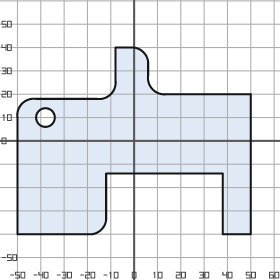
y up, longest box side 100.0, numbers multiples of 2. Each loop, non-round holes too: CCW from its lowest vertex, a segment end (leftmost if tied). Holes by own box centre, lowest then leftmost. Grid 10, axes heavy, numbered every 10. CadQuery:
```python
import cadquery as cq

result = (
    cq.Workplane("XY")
    .moveTo(-50.0, -40.0)
    .lineTo(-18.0, -40.0)
    .threePointArc((-14.0, -38.0), (-12.0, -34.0))
    .lineTo(-12.0, -14.0)
    .lineTo(38.0, -14.0)
    .lineTo(38.0, -40.0)
    .lineTo(50.0, -40.0)
    .lineTo(50.0, 20.0)
    .lineTo(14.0, 20.0)
    .threePointArc((8.0, 22.0), (6.0, 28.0))
    .lineTo(6.0, 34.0)
    .threePointArc((4.0, 38.0), (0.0, 40.0))
    .lineTo(-8.0, 40.0)
    .lineTo(-8.0, 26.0)
    .threePointArc((-10.0, 20.0), (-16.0, 18.0))
    .lineTo(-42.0, 18.0)
    .threePointArc((-48.0, 16.0), (-50.0, 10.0))
    .close()
    .moveTo(-38.0, 10.0)
    .circle(4.0)
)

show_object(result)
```